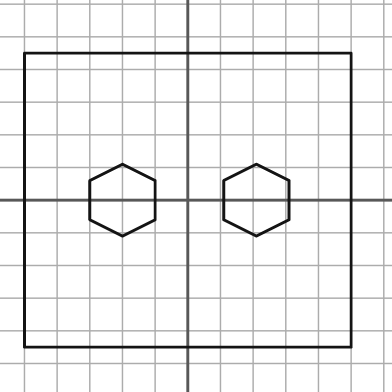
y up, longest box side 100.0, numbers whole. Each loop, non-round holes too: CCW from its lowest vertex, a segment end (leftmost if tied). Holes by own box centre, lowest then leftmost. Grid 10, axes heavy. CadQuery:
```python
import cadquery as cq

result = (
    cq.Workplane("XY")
    .moveTo(-50.0, -45.0)
    .lineTo(50.0, -45.0)
    .lineTo(50.0, 45.0)
    .lineTo(-50.0, 45.0)
    .close()
    .moveTo(-20.0, -11.0)
    .lineTo(-10.0, -6.0)
    .lineTo(-10.0, 6.0)
    .lineTo(-20.0, 11.0)
    .lineTo(-30.0, 6.0)
    .lineTo(-30.0, -6.0)
    .close()
    .moveTo(21.0, -11.0)
    .lineTo(31.0, -6.0)
    .lineTo(31.0, 6.0)
    .lineTo(21.0, 11.0)
    .lineTo(11.0, 6.0)
    .lineTo(11.0, -6.0)
    .close()
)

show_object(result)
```